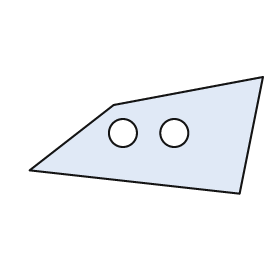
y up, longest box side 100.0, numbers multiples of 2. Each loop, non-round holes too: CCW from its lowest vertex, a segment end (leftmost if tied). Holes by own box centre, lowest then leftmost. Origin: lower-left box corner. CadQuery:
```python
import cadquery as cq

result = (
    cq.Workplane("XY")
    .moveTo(90.0, 0.0)
    .lineTo(100.0, 50.0)
    .lineTo(36.0, 38.0)
    .lineTo(0.0, 10.0)
    .close()
    .moveTo(40.0, 26.0)
    .circle(6.0)
    .moveTo(62.0, 26.0)
    .circle(6.0)
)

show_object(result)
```